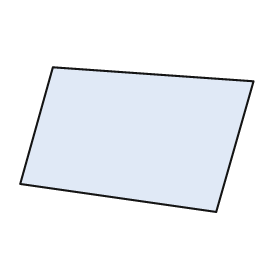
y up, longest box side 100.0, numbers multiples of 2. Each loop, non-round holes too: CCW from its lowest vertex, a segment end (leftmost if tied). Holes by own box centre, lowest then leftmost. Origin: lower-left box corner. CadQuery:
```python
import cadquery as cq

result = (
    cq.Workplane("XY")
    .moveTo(84.0, 0.0)
    .lineTo(100.0, 56.0)
    .lineTo(14.0, 62.0)
    .lineTo(0.0, 12.0)
    .close()
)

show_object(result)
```